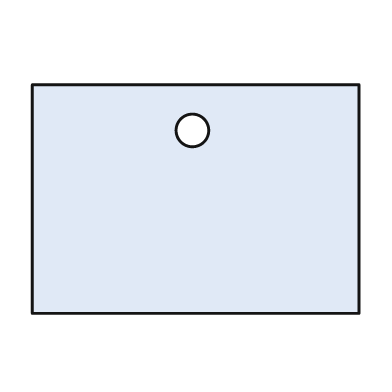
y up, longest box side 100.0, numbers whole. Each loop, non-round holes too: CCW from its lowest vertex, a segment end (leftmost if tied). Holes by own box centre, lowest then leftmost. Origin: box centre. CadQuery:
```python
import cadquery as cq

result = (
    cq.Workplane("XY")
    .moveTo(-50.0, -35.0)
    .lineTo(50.0, -35.0)
    .lineTo(50.0, 35.0)
    .lineTo(-50.0, 35.0)
    .close()
    .moveTo(-1.0, 21.0)
    .circle(5.0)
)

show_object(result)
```